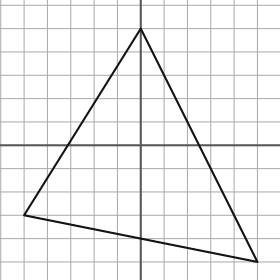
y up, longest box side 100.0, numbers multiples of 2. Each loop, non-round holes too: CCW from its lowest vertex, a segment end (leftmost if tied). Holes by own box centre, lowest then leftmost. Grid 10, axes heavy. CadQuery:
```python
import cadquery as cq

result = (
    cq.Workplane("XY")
    .moveTo(50.0, -50.0)
    .lineTo(0.0, 50.0)
    .lineTo(-50.0, -30.0)
    .close()
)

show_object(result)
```